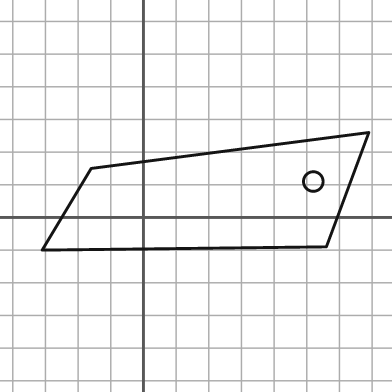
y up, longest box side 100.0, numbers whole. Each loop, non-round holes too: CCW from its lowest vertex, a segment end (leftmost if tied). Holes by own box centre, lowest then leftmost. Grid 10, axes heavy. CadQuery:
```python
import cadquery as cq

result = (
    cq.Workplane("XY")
    .moveTo(-31.0, -10.0)
    .lineTo(56.0, -9.0)
    .lineTo(69.0, 26.0)
    .lineTo(-16.0, 15.0)
    .close()
    .moveTo(52.0, 11.0)
    .circle(3.0)
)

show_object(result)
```